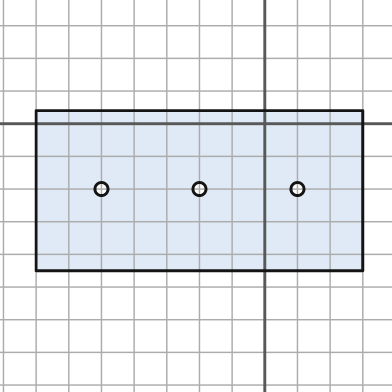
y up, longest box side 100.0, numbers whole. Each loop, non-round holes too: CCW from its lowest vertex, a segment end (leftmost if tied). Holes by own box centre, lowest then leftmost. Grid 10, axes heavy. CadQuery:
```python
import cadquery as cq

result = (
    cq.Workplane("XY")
    .moveTo(-70.0, -45.0)
    .lineTo(30.0, -45.0)
    .lineTo(30.0, 4.0)
    .lineTo(-70.0, 4.0)
    .close()
    .moveTo(-50.0, -20.0)
    .circle(2.0)
    .moveTo(-20.0, -20.0)
    .circle(2.0)
    .moveTo(10.0, -20.0)
    .circle(2.0)
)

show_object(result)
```